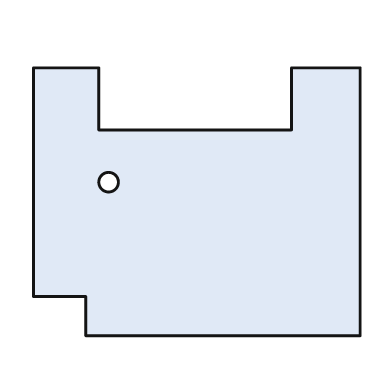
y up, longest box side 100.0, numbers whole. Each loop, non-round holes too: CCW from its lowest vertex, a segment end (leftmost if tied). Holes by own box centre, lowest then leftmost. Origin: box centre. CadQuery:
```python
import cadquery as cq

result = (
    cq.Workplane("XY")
    .moveTo(-34.0, -41.0)
    .lineTo(50.0, -41.0)
    .lineTo(50.0, 41.0)
    .lineTo(29.0, 41.0)
    .lineTo(29.0, 22.0)
    .lineTo(-30.0, 22.0)
    .lineTo(-30.0, 41.0)
    .lineTo(-50.0, 41.0)
    .lineTo(-50.0, -29.0)
    .lineTo(-34.0, -29.0)
    .close()
    .moveTo(-27.0, 6.0)
    .circle(3.0)
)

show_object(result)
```